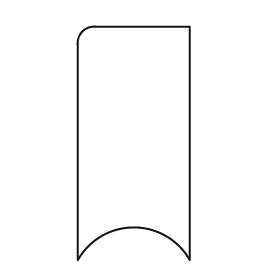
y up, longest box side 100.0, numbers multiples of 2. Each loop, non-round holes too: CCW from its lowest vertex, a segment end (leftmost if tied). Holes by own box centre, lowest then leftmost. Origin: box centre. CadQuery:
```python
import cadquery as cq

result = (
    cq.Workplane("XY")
    .moveTo(-24.0, -50.0)
    .threePointArc((0.0, -36.0), (24.0, -50.0))
    .lineTo(24.0, 50.0)
    .lineTo(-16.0, 50.0)
    .threePointArc((-22.0, 48.0), (-24.0, 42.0))
    .close()
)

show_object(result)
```